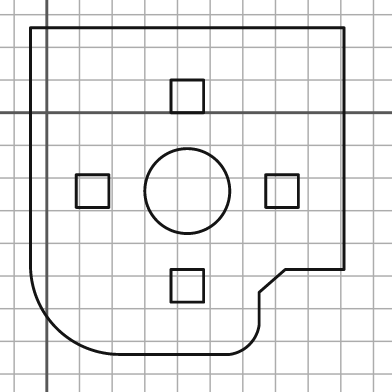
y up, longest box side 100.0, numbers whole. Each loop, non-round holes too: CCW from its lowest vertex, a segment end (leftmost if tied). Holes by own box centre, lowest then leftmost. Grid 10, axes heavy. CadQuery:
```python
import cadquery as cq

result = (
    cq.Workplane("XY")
    .moveTo(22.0, -74.0)
    .lineTo(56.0, -74.0)
    .threePointArc((62.0, -71.0), (65.0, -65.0))
    .lineTo(65.0, -55.0)
    .lineTo(73.0, -48.0)
    .lineTo(91.0, -48.0)
    .lineTo(91.0, 26.0)
    .lineTo(-5.0, 26.0)
    .lineTo(-5.0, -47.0)
    .threePointArc((3.0, -66.0), (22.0, -74.0))
    .close()
    .moveTo(38.0, -58.0)
    .lineTo(48.0, -58.0)
    .lineTo(48.0, -48.0)
    .lineTo(38.0, -48.0)
    .close()
    .moveTo(9.0, -29.0)
    .lineTo(19.0, -29.0)
    .lineTo(19.0, -19.0)
    .lineTo(9.0, -19.0)
    .close()
    .moveTo(43.0, -24.0)
    .circle(13.0)
    .moveTo(67.0, -29.0)
    .lineTo(77.0, -29.0)
    .lineTo(77.0, -19.0)
    .lineTo(67.0, -19.0)
    .close()
    .moveTo(38.0, 0.0)
    .lineTo(48.0, 0.0)
    .lineTo(48.0, 10.0)
    .lineTo(38.0, 10.0)
    .close()
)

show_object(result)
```